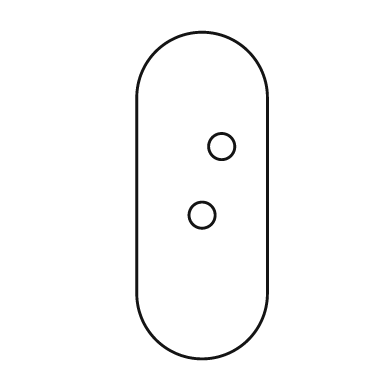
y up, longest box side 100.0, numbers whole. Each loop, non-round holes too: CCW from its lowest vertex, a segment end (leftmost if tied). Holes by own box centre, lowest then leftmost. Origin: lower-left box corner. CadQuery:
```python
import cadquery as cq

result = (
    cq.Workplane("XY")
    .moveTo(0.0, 20.0)
    .threePointArc((20.0, 0.0), (40.0, 20.0))
    .lineTo(40.0, 80.0)
    .threePointArc((20.0, 100.0), (0.0, 80.0))
    .close()
    .moveTo(20.0, 44.0)
    .circle(4.0)
    .moveTo(26.0, 65.0)
    .circle(4.0)
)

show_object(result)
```